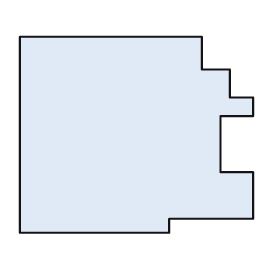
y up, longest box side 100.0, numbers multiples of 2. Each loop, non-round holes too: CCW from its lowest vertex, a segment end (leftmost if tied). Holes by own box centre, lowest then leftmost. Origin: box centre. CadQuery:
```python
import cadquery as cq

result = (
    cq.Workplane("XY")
    .moveTo(-50.0, -42.0)
    .lineTo(14.0, -42.0)
    .lineTo(14.0, -36.0)
    .lineTo(50.0, -36.0)
    .lineTo(50.0, -16.0)
    .lineTo(36.0, -16.0)
    .lineTo(36.0, 8.0)
    .lineTo(50.0, 8.0)
    .lineTo(50.0, 16.0)
    .lineTo(40.0, 16.0)
    .lineTo(40.0, 28.0)
    .lineTo(28.0, 28.0)
    .lineTo(28.0, 42.0)
    .lineTo(-50.0, 42.0)
    .close()
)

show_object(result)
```